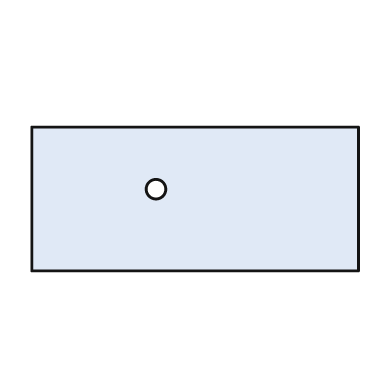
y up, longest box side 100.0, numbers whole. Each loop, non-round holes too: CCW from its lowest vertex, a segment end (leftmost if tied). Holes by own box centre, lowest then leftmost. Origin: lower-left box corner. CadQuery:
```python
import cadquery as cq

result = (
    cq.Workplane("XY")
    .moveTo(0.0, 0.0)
    .lineTo(100.0, 0.0)
    .lineTo(100.0, 44.0)
    .lineTo(0.0, 44.0)
    .close()
    .moveTo(38.0, 25.0)
    .circle(3.0)
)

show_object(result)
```